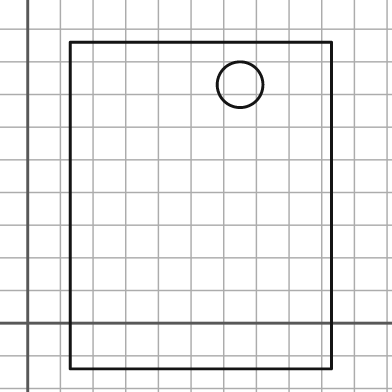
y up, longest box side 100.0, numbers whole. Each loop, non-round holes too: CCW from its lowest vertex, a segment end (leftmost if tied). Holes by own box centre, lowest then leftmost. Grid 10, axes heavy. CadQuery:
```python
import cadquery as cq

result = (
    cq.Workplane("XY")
    .moveTo(13.0, -14.0)
    .lineTo(93.0, -14.0)
    .lineTo(93.0, 86.0)
    .lineTo(13.0, 86.0)
    .close()
    .moveTo(65.0, 73.0)
    .circle(7.0)
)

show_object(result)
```